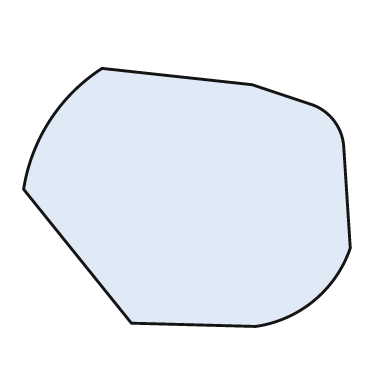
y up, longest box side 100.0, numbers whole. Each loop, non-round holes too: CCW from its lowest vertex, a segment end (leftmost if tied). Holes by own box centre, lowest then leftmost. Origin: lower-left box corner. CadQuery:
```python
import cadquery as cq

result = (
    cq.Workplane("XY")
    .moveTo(71.0, 0.0)
    .threePointArc((89.0, 8.0), (100.0, 24.0))
    .lineTo(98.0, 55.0)
    .threePointArc((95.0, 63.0), (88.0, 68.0))
    .lineTo(70.0, 74.0)
    .lineTo(24.0, 79.0)
    .threePointArc((8.0, 63.0), (0.0, 42.0))
    .lineTo(33.0, 1.0)
    .close()
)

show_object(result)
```